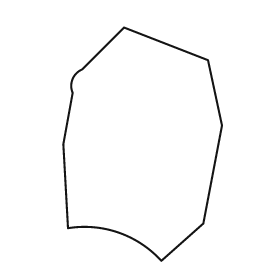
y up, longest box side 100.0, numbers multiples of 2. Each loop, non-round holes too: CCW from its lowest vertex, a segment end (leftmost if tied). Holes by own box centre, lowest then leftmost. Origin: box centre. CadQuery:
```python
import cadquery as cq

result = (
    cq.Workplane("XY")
    .moveTo(8.0, -50.0)
    .lineTo(26.0, -34.0)
    .lineTo(34.0, 8.0)
    .lineTo(28.0, 36.0)
    .lineTo(-8.0, 50.0)
    .lineTo(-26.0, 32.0)
    .threePointArc((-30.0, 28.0), (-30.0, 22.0))
    .lineTo(-34.0, 0.0)
    .lineTo(-32.0, -36.0)
    .threePointArc((-10.0, -38.0), (8.0, -50.0))
    .close()
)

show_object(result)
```